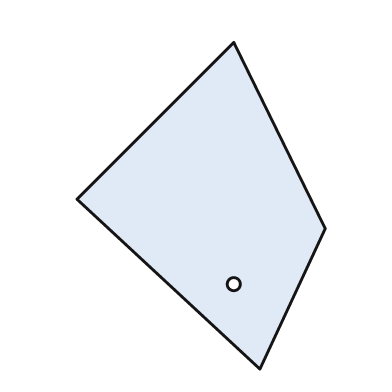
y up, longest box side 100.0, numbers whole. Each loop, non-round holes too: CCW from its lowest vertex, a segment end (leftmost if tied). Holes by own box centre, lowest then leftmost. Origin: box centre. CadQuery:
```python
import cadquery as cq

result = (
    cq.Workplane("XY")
    .moveTo(18.0, -50.0)
    .lineTo(38.0, -7.0)
    .lineTo(10.0, 50.0)
    .lineTo(-38.0, 2.0)
    .close()
    .moveTo(10.0, -24.0)
    .circle(2.0)
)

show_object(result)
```